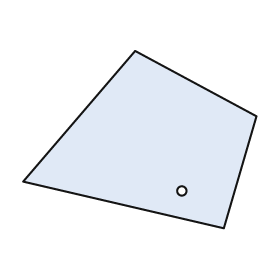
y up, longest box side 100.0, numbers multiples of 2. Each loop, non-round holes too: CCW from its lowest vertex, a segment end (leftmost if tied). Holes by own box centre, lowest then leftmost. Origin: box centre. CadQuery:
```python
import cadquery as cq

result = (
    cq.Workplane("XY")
    .moveTo(36.0, -38.0)
    .lineTo(50.0, 10.0)
    .lineTo(-2.0, 38.0)
    .lineTo(-50.0, -18.0)
    .close()
    .moveTo(18.0, -22.0)
    .circle(2.0)
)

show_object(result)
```